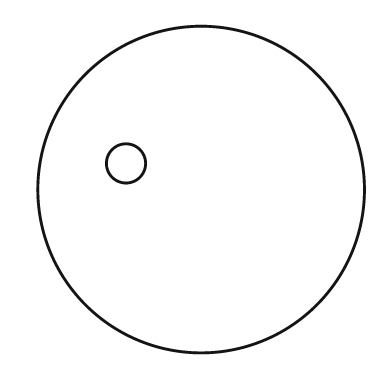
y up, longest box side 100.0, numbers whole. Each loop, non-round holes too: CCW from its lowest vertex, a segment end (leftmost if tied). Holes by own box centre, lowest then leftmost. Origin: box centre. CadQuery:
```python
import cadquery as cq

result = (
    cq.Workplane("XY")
    .moveTo(0.0, 0.0)
    .circle(50.0)
    .moveTo(-23.0, 8.0)
    .circle(6.0)
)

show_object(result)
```